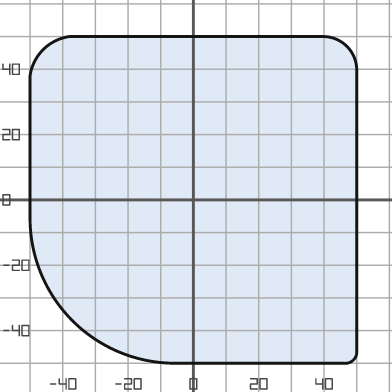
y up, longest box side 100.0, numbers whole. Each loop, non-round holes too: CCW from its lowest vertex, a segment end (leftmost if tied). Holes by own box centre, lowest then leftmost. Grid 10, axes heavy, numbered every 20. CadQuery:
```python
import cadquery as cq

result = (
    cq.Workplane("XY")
    .moveTo(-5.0, -50.0)
    .lineTo(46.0, -50.0)
    .threePointArc((49.0, -49.0), (50.0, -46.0))
    .lineTo(50.0, 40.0)
    .threePointArc((47.0, 47.0), (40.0, 50.0))
    .lineTo(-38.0, 50.0)
    .threePointArc((-46.0, 46.0), (-50.0, 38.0))
    .lineTo(-50.0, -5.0)
    .threePointArc((-37.0, -37.0), (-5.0, -50.0))
    .close()
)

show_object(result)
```